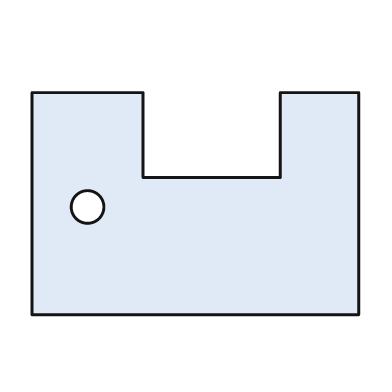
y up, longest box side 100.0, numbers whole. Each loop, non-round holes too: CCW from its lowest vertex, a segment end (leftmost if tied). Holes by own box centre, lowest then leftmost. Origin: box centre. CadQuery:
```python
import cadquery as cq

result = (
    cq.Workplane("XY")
    .moveTo(-50.0, -34.0)
    .lineTo(50.0, -34.0)
    .lineTo(50.0, 34.0)
    .lineTo(26.0, 34.0)
    .lineTo(26.0, 8.0)
    .lineTo(-16.0, 8.0)
    .lineTo(-16.0, 34.0)
    .lineTo(-50.0, 34.0)
    .close()
    .moveTo(-33.0, -1.0)
    .circle(5.0)
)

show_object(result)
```